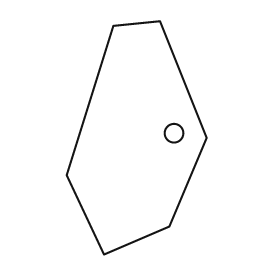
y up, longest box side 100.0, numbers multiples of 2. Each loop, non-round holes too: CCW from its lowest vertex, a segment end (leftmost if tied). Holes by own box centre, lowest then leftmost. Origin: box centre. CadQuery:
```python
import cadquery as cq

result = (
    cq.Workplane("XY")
    .moveTo(-14.0, -50.0)
    .lineTo(14.0, -38.0)
    .lineTo(30.0, 0.0)
    .lineTo(10.0, 50.0)
    .lineTo(-10.0, 48.0)
    .lineTo(-30.0, -16.0)
    .close()
    .moveTo(16.0, 2.0)
    .circle(4.0)
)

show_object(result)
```